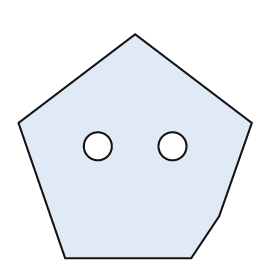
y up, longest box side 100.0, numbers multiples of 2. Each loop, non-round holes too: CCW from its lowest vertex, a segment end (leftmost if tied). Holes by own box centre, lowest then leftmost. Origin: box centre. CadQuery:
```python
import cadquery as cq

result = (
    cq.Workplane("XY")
    .moveTo(-30.0, -48.0)
    .lineTo(24.0, -48.0)
    .lineTo(36.0, -30.0)
    .lineTo(50.0, 10.0)
    .lineTo(0.0, 48.0)
    .lineTo(-50.0, 10.0)
    .close()
    .moveTo(-16.0, 0.0)
    .circle(6.0)
    .moveTo(16.0, 0.0)
    .circle(6.0)
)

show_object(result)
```